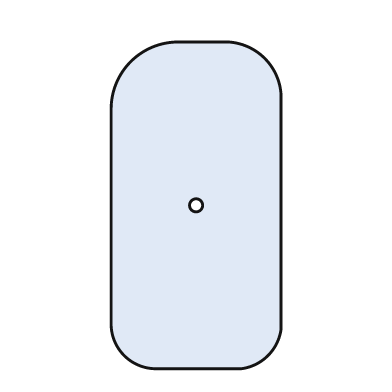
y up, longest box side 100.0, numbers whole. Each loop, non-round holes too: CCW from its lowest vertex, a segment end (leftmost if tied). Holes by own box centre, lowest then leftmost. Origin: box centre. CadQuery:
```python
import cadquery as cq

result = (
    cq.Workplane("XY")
    .moveTo(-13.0, -50.0)
    .lineTo(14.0, -50.0)
    .threePointArc((22.0, -46.0), (26.0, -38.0))
    .lineTo(26.0, 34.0)
    .threePointArc((21.0, 45.0), (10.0, 50.0))
    .lineTo(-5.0, 50.0)
    .threePointArc((-20.0, 44.0), (-26.0, 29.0))
    .lineTo(-26.0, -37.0)
    .threePointArc((-22.0, -46.0), (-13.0, -50.0))
    .close()
    .moveTo(0.0, 0.0)
    .circle(2.0)
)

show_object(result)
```